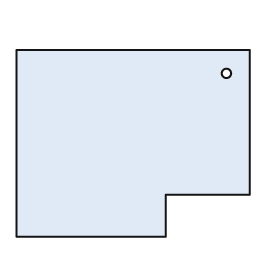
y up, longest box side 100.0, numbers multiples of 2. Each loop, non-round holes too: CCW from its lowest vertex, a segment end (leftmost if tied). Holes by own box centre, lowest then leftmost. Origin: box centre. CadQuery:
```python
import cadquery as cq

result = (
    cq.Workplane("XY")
    .moveTo(-50.0, -40.0)
    .lineTo(14.0, -40.0)
    .lineTo(14.0, -22.0)
    .lineTo(50.0, -22.0)
    .lineTo(50.0, 40.0)
    .lineTo(-50.0, 40.0)
    .close()
    .moveTo(40.0, 30.0)
    .circle(2.0)
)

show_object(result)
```